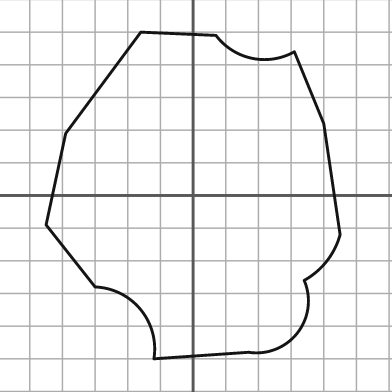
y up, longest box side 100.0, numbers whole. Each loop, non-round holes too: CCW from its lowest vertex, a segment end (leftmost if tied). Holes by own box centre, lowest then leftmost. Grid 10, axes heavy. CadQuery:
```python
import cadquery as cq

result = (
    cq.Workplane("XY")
    .moveTo(-12.0, -50.0)
    .lineTo(17.0, -48.0)
    .threePointArc((32.0, -42.0), (34.0, -26.0))
    .threePointArc((41.0, -20.0), (45.0, -12.0))
    .lineTo(40.0, 22.0)
    .lineTo(31.0, 44.0)
    .threePointArc((18.0, 42.0), (7.0, 49.0))
    .lineTo(-16.0, 50.0)
    .lineTo(-39.0, 19.0)
    .lineTo(-45.0, -9.0)
    .lineTo(-30.0, -28.0)
    .threePointArc((-16.0, -35.0), (-12.0, -50.0))
    .close()
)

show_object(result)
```